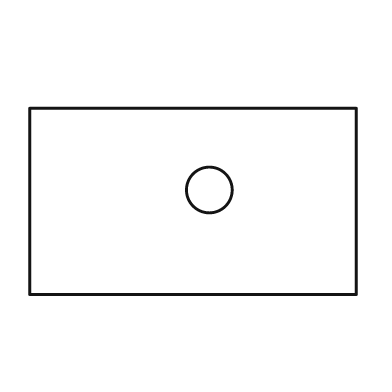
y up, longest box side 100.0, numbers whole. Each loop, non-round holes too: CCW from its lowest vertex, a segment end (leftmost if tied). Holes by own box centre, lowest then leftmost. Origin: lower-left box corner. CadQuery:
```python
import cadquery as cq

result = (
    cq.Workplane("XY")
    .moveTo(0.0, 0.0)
    .lineTo(100.0, 0.0)
    .lineTo(100.0, 57.0)
    .lineTo(0.0, 57.0)
    .close()
    .moveTo(55.0, 32.0)
    .circle(7.0)
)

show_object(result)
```